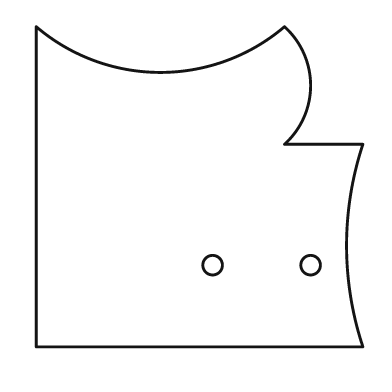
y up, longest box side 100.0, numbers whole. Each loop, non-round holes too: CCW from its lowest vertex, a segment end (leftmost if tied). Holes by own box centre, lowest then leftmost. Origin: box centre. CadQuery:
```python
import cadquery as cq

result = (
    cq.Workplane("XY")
    .moveTo(-50.0, -49.0)
    .lineTo(50.0, -49.0)
    .threePointArc((45.0, -18.0), (50.0, 13.0))
    .lineTo(26.0, 13.0)
    .threePointArc((34.0, 31.0), (26.0, 49.0))
    .threePointArc((-12.0, 35.0), (-50.0, 49.0))
    .close()
    .moveTo(4.0, -24.0)
    .circle(3.0)
    .moveTo(34.0, -24.0)
    .circle(3.0)
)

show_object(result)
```